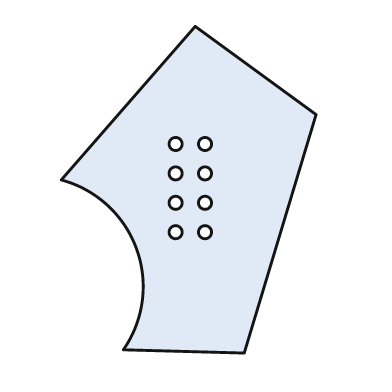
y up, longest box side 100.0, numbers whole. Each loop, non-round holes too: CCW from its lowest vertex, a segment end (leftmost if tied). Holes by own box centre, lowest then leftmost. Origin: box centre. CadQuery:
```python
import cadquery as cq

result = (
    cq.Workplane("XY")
    .moveTo(17.0, -50.0)
    .lineTo(39.0, 23.0)
    .lineTo(2.0, 50.0)
    .lineTo(-39.0, 3.0)
    .threePointArc((-16.0, -18.0), (-20.0, -49.0))
    .close()
    .moveTo(-4.0, -13.0)
    .circle(2.0)
    .moveTo(5.0, -13.0)
    .circle(2.0)
    .moveTo(-4.0, -4.0)
    .circle(2.0)
    .moveTo(5.0, -4.0)
    .circle(2.0)
    .moveTo(-4.0, 5.0)
    .circle(2.0)
    .moveTo(5.0, 5.0)
    .circle(2.0)
    .moveTo(-4.0, 14.0)
    .circle(2.0)
    .moveTo(5.0, 14.0)
    .circle(2.0)
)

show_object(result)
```